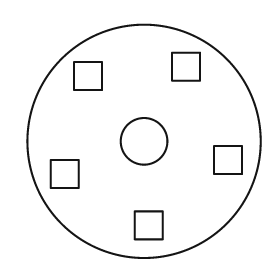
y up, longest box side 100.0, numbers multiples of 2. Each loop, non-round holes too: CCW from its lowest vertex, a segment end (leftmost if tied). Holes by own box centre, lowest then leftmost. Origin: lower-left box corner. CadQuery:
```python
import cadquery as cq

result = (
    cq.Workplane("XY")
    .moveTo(50.0, 50.0)
    .circle(50.0)
    .moveTo(46.0, 8.0)
    .lineTo(58.0, 8.0)
    .lineTo(58.0, 20.0)
    .lineTo(46.0, 20.0)
    .close()
    .moveTo(10.0, 30.0)
    .lineTo(22.0, 30.0)
    .lineTo(22.0, 42.0)
    .lineTo(10.0, 42.0)
    .close()
    .moveTo(80.0, 36.0)
    .lineTo(92.0, 36.0)
    .lineTo(92.0, 48.0)
    .lineTo(80.0, 48.0)
    .close()
    .moveTo(50.0, 50.0)
    .circle(10.0)
    .moveTo(20.0, 72.0)
    .lineTo(32.0, 72.0)
    .lineTo(32.0, 84.0)
    .lineTo(20.0, 84.0)
    .close()
    .moveTo(62.0, 76.0)
    .lineTo(74.0, 76.0)
    .lineTo(74.0, 88.0)
    .lineTo(62.0, 88.0)
    .close()
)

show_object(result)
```